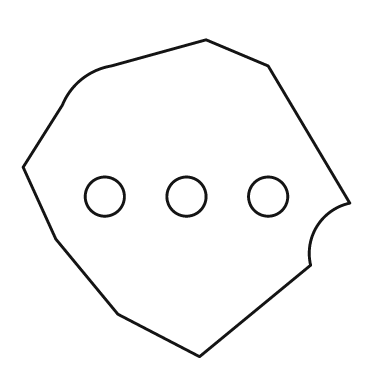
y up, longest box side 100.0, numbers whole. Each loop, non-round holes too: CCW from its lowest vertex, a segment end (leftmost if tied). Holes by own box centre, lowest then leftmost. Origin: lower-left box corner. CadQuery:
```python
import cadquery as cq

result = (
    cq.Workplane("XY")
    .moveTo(54.0, 0.0)
    .lineTo(88.0, 28.0)
    .threePointArc((90.0, 40.0), (100.0, 47.0))
    .lineTo(75.0, 89.0)
    .lineTo(56.0, 97.0)
    .lineTo(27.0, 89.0)
    .threePointArc((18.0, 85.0), (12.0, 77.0))
    .lineTo(0.0, 58.0)
    .lineTo(10.0, 36.0)
    .lineTo(29.0, 13.0)
    .close()
    .moveTo(25.0, 49.0)
    .circle(6.0)
    .moveTo(50.0, 49.0)
    .circle(6.0)
    .moveTo(75.0, 49.0)
    .circle(6.0)
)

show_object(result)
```